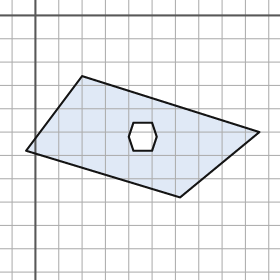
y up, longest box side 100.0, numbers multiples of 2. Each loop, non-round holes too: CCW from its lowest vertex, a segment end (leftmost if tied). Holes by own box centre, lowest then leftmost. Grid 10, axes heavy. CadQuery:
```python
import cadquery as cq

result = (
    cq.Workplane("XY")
    .moveTo(62.0, -78.0)
    .lineTo(96.0, -50.0)
    .lineTo(20.0, -26.0)
    .lineTo(-4.0, -58.0)
    .close()
    .moveTo(42.0, -58.0)
    .lineTo(50.0, -58.0)
    .lineTo(52.0, -52.0)
    .lineTo(50.0, -46.0)
    .lineTo(42.0, -46.0)
    .lineTo(40.0, -52.0)
    .close()
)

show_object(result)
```